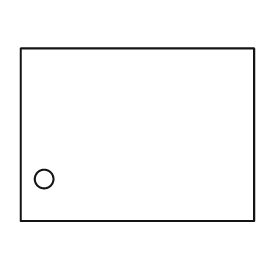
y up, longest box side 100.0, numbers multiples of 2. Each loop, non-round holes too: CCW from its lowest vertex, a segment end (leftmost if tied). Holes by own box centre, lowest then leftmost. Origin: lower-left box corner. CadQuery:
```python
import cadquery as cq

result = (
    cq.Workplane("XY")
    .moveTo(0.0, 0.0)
    .lineTo(100.0, 0.0)
    .lineTo(100.0, 74.0)
    .lineTo(0.0, 74.0)
    .close()
    .moveTo(10.0, 18.0)
    .circle(4.0)
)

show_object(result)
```